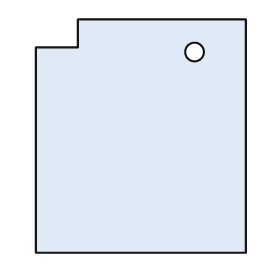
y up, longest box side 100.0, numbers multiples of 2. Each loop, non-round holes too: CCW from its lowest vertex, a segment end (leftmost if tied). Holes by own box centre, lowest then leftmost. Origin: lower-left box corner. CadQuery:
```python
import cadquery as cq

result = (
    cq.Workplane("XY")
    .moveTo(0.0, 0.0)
    .lineTo(90.0, 0.0)
    .lineTo(90.0, 100.0)
    .lineTo(18.0, 100.0)
    .lineTo(18.0, 88.0)
    .lineTo(0.0, 88.0)
    .close()
    .moveTo(68.0, 86.0)
    .circle(4.0)
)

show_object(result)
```